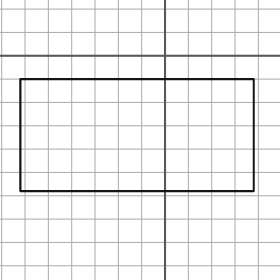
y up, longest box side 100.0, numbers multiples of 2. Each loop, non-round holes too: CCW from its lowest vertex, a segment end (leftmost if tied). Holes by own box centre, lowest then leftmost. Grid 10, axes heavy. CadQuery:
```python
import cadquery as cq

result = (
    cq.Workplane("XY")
    .moveTo(-62.0, -58.0)
    .lineTo(38.0, -58.0)
    .lineTo(38.0, -10.0)
    .lineTo(-62.0, -10.0)
    .close()
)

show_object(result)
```